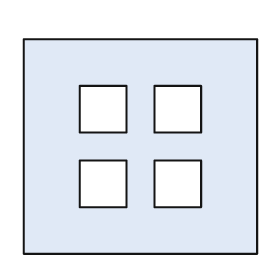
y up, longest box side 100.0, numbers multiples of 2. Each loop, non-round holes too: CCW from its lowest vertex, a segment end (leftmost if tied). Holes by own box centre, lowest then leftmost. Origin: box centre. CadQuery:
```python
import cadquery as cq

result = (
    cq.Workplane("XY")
    .moveTo(-50.0, -46.0)
    .lineTo(50.0, -46.0)
    .lineTo(50.0, 46.0)
    .lineTo(-50.0, 46.0)
    .close()
    .moveTo(-26.0, -26.0)
    .lineTo(-6.0, -26.0)
    .lineTo(-6.0, -6.0)
    .lineTo(-26.0, -6.0)
    .close()
    .moveTo(6.0, -26.0)
    .lineTo(26.0, -26.0)
    .lineTo(26.0, -6.0)
    .lineTo(6.0, -6.0)
    .close()
    .moveTo(-26.0, 6.0)
    .lineTo(-6.0, 6.0)
    .lineTo(-6.0, 26.0)
    .lineTo(-26.0, 26.0)
    .close()
    .moveTo(6.0, 6.0)
    .lineTo(26.0, 6.0)
    .lineTo(26.0, 26.0)
    .lineTo(6.0, 26.0)
    .close()
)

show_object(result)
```